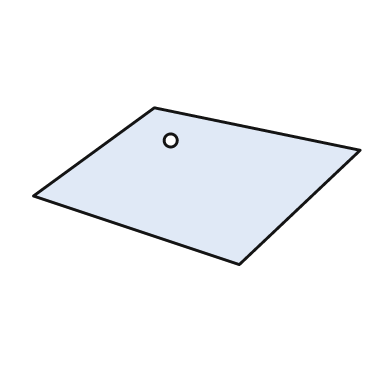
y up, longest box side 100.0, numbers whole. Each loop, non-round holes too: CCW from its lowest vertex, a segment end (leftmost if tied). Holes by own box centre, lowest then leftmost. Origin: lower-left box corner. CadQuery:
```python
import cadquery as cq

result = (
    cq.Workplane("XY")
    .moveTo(63.0, 0.0)
    .lineTo(100.0, 35.0)
    .lineTo(37.0, 48.0)
    .lineTo(0.0, 21.0)
    .close()
    .moveTo(42.0, 38.0)
    .circle(2.0)
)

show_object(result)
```